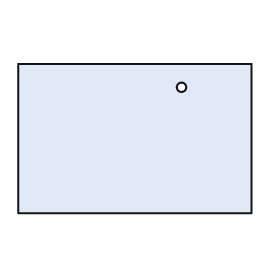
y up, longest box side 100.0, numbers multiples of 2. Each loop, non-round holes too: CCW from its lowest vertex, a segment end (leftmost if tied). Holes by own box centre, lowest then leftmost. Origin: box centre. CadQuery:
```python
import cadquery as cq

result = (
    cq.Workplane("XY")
    .moveTo(-50.0, -32.0)
    .lineTo(50.0, -32.0)
    .lineTo(50.0, 32.0)
    .lineTo(-50.0, 32.0)
    .close()
    .moveTo(20.0, 22.0)
    .circle(2.0)
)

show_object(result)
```